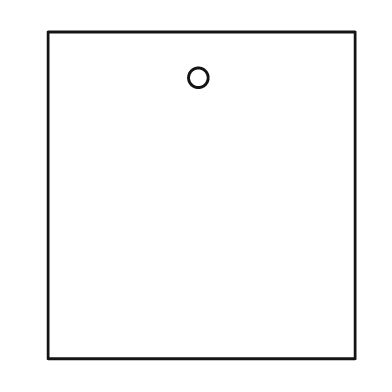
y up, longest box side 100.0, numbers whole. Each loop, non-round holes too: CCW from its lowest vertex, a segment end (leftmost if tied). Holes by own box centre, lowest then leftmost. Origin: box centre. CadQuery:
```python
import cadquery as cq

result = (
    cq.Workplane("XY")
    .moveTo(-47.0, -50.0)
    .lineTo(47.0, -50.0)
    .lineTo(47.0, 50.0)
    .lineTo(-47.0, 50.0)
    .close()
    .moveTo(-1.0, 36.0)
    .circle(3.0)
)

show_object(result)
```